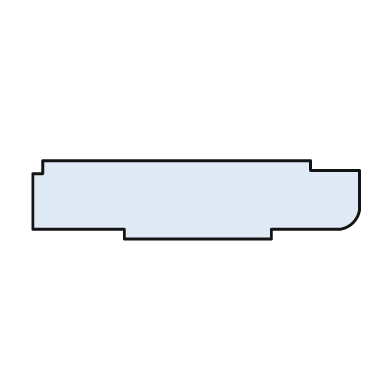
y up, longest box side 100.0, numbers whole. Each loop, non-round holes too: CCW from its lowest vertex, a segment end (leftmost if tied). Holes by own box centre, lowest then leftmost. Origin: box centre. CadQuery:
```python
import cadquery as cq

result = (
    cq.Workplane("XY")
    .moveTo(-22.0, -12.0)
    .lineTo(23.0, -12.0)
    .lineTo(23.0, -9.0)
    .lineTo(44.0, -9.0)
    .threePointArc((48.0, -7.0), (50.0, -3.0))
    .lineTo(50.0, 9.0)
    .lineTo(35.0, 9.0)
    .lineTo(35.0, 12.0)
    .lineTo(-47.0, 12.0)
    .lineTo(-47.0, 8.0)
    .lineTo(-50.0, 8.0)
    .lineTo(-50.0, -9.0)
    .lineTo(-22.0, -9.0)
    .close()
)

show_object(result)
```